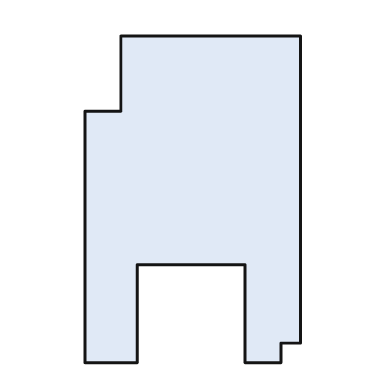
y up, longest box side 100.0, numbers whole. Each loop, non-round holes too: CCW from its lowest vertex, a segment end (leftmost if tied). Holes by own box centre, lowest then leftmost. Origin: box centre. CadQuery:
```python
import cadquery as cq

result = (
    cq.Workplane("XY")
    .moveTo(-33.0, -50.0)
    .lineTo(-17.0, -50.0)
    .lineTo(-17.0, -20.0)
    .lineTo(16.0, -20.0)
    .lineTo(16.0, -50.0)
    .lineTo(27.0, -50.0)
    .lineTo(27.0, -44.0)
    .lineTo(33.0, -44.0)
    .lineTo(33.0, 50.0)
    .lineTo(-22.0, 50.0)
    .lineTo(-22.0, 27.0)
    .lineTo(-33.0, 27.0)
    .close()
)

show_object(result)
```